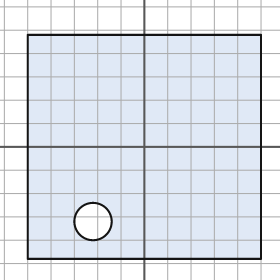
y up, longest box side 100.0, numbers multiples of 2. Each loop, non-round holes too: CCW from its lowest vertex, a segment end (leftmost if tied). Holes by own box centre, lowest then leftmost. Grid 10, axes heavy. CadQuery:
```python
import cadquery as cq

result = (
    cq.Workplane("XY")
    .moveTo(-50.0, -48.0)
    .lineTo(50.0, -48.0)
    .lineTo(50.0, 48.0)
    .lineTo(-50.0, 48.0)
    .close()
    .moveTo(-22.0, -32.0)
    .circle(8.0)
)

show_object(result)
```